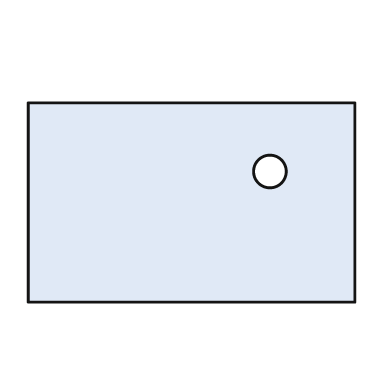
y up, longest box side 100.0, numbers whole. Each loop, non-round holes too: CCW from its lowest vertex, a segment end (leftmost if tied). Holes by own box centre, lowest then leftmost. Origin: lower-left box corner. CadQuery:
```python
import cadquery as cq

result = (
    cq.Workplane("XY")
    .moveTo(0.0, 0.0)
    .lineTo(100.0, 0.0)
    .lineTo(100.0, 61.0)
    .lineTo(0.0, 61.0)
    .close()
    .moveTo(74.0, 40.0)
    .circle(5.0)
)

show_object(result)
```